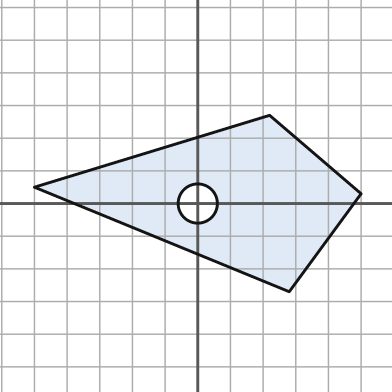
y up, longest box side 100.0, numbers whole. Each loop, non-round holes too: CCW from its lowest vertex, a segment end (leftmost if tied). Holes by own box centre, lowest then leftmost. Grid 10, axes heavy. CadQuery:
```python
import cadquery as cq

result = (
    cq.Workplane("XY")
    .moveTo(28.0, -27.0)
    .lineTo(50.0, 3.0)
    .lineTo(22.0, 27.0)
    .lineTo(-50.0, 5.0)
    .close()
    .moveTo(0.0, 0.0)
    .circle(6.0)
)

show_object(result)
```